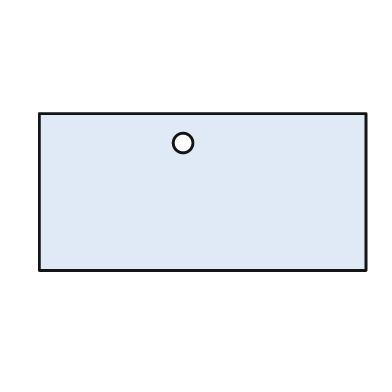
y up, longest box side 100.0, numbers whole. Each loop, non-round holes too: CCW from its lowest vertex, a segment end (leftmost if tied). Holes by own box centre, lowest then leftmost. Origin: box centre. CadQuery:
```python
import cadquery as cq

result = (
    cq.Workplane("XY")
    .moveTo(-50.0, -24.0)
    .lineTo(50.0, -24.0)
    .lineTo(50.0, 24.0)
    .lineTo(-50.0, 24.0)
    .close()
    .moveTo(-6.0, 15.0)
    .circle(3.0)
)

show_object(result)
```